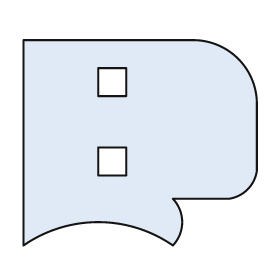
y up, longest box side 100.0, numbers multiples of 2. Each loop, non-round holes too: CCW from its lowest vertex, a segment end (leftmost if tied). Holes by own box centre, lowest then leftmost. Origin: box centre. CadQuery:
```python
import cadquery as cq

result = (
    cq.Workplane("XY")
    .moveTo(-50.0, -44.0)
    .threePointArc((-18.0, -34.0), (14.0, -44.0))
    .threePointArc((18.0, -34.0), (14.0, -24.0))
    .lineTo(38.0, -24.0)
    .threePointArc((46.0, -20.0), (50.0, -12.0))
    .lineTo(50.0, 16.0)
    .threePointArc((42.0, 36.0), (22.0, 44.0))
    .lineTo(-50.0, 44.0)
    .close()
    .moveTo(-18.0, -14.0)
    .lineTo(-6.0, -14.0)
    .lineTo(-6.0, -2.0)
    .lineTo(-18.0, -2.0)
    .close()
    .moveTo(-18.0, 20.0)
    .lineTo(-6.0, 20.0)
    .lineTo(-6.0, 32.0)
    .lineTo(-18.0, 32.0)
    .close()
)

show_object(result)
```